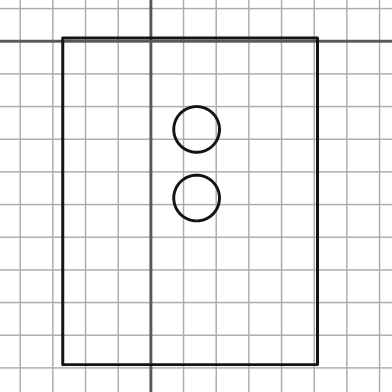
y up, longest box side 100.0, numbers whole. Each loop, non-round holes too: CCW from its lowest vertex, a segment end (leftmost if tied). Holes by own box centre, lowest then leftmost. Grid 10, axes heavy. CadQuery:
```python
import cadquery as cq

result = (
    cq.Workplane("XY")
    .moveTo(-27.0, -99.0)
    .lineTo(51.0, -99.0)
    .lineTo(51.0, 1.0)
    .lineTo(-27.0, 1.0)
    .close()
    .moveTo(14.0, -48.0)
    .circle(7.0)
    .moveTo(14.0, -27.0)
    .circle(7.0)
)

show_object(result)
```